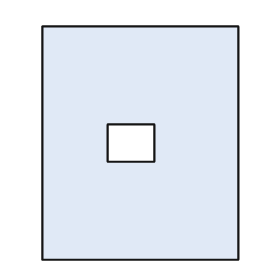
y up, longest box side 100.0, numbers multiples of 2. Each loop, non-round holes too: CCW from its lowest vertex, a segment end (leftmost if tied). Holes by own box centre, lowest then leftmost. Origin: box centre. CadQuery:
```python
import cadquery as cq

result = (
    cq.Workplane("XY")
    .moveTo(-42.0, -50.0)
    .lineTo(42.0, -50.0)
    .lineTo(42.0, 50.0)
    .lineTo(-42.0, 50.0)
    .close()
    .moveTo(-14.0, -8.0)
    .lineTo(6.0, -8.0)
    .lineTo(6.0, 8.0)
    .lineTo(-14.0, 8.0)
    .close()
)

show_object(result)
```